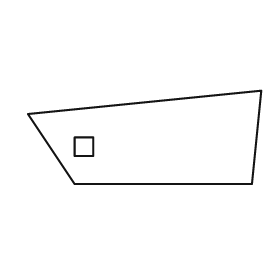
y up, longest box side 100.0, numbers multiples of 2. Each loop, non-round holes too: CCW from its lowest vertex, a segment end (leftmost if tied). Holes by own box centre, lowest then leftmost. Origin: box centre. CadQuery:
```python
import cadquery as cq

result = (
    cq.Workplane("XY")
    .moveTo(-30.0, -20.0)
    .lineTo(46.0, -20.0)
    .lineTo(50.0, 20.0)
    .lineTo(-50.0, 10.0)
    .close()
    .moveTo(-30.0, -8.0)
    .lineTo(-22.0, -8.0)
    .lineTo(-22.0, 0.0)
    .lineTo(-30.0, 0.0)
    .close()
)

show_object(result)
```